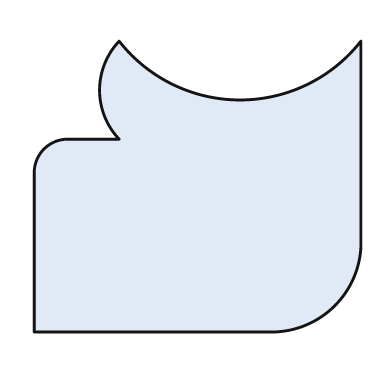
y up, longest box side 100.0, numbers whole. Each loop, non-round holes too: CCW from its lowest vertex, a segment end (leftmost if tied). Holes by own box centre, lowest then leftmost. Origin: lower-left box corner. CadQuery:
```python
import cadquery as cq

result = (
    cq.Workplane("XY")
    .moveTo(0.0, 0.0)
    .lineTo(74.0, 0.0)
    .threePointArc((92.0, 8.0), (100.0, 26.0))
    .lineTo(100.0, 89.0)
    .threePointArc((63.0, 71.0), (26.0, 89.0))
    .threePointArc((20.0, 74.0), (26.0, 59.0))
    .lineTo(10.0, 59.0)
    .threePointArc((3.0, 56.0), (0.0, 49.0))
    .close()
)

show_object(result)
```